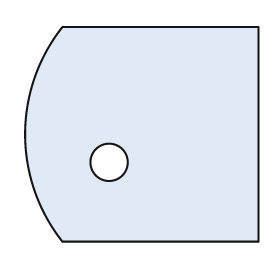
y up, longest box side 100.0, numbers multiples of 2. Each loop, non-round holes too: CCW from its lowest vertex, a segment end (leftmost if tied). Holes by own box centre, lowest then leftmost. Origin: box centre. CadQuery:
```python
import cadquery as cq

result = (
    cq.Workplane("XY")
    .moveTo(-34.0, -46.0)
    .lineTo(50.0, -46.0)
    .lineTo(50.0, 46.0)
    .lineTo(-34.0, 46.0)
    .threePointArc((-50.0, 0.0), (-34.0, -46.0))
    .close()
    .moveTo(-14.0, -12.0)
    .circle(8.0)
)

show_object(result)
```